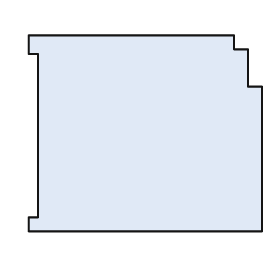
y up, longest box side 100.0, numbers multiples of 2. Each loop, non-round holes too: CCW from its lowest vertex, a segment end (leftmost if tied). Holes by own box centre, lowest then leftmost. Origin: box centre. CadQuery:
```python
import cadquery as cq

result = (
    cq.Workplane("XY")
    .moveTo(-50.0, -42.0)
    .lineTo(50.0, -42.0)
    .lineTo(50.0, 20.0)
    .lineTo(44.0, 20.0)
    .lineTo(44.0, 36.0)
    .lineTo(38.0, 36.0)
    .lineTo(38.0, 42.0)
    .lineTo(-50.0, 42.0)
    .lineTo(-50.0, 34.0)
    .lineTo(-46.0, 34.0)
    .lineTo(-46.0, -36.0)
    .lineTo(-50.0, -36.0)
    .close()
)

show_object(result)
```